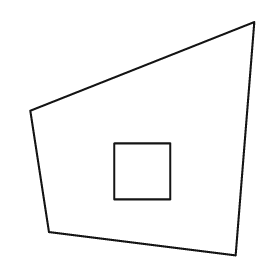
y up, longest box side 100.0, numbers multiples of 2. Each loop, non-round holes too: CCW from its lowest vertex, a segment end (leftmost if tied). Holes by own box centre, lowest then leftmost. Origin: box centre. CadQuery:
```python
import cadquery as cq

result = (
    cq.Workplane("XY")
    .moveTo(40.0, -50.0)
    .lineTo(48.0, 50.0)
    .lineTo(-48.0, 12.0)
    .lineTo(-40.0, -40.0)
    .close()
    .moveTo(-12.0, -26.0)
    .lineTo(12.0, -26.0)
    .lineTo(12.0, -2.0)
    .lineTo(-12.0, -2.0)
    .close()
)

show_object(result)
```